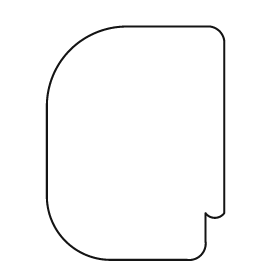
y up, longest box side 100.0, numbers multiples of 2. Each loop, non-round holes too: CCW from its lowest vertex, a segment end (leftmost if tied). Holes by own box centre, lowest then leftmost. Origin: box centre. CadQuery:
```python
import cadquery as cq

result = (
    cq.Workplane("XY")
    .moveTo(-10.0, -50.0)
    .lineTo(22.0, -50.0)
    .threePointArc((28.0, -48.0), (30.0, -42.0))
    .lineTo(30.0, -30.0)
    .threePointArc((34.0, -32.0), (38.0, -30.0))
    .lineTo(38.0, 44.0)
    .threePointArc((36.0, 48.0), (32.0, 50.0))
    .lineTo(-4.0, 50.0)
    .threePointArc((-28.0, 40.0), (-38.0, 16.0))
    .lineTo(-38.0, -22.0)
    .threePointArc((-30.0, -42.0), (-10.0, -50.0))
    .close()
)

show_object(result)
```